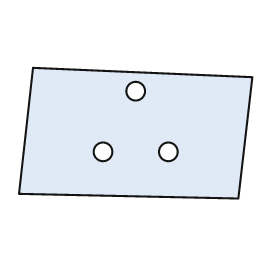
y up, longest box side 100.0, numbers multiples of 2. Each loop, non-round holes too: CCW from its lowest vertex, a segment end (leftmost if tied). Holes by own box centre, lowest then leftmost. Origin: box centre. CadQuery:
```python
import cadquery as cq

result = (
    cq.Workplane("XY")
    .moveTo(44.0, -28.0)
    .lineTo(50.0, 24.0)
    .lineTo(-44.0, 28.0)
    .lineTo(-50.0, -26.0)
    .close()
    .moveTo(-14.0, -8.0)
    .circle(4.0)
    .moveTo(14.0, -8.0)
    .circle(4.0)
    .moveTo(0.0, 18.0)
    .circle(4.0)
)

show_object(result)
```